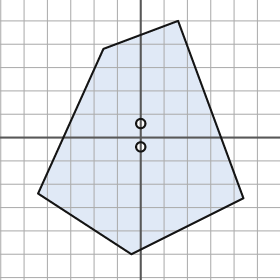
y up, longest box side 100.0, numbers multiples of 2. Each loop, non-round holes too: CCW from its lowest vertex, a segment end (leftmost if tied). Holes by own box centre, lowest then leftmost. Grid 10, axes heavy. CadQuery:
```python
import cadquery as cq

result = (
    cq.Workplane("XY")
    .moveTo(-4.0, -50.0)
    .lineTo(44.0, -26.0)
    .lineTo(16.0, 50.0)
    .lineTo(-16.0, 38.0)
    .lineTo(-44.0, -24.0)
    .close()
    .moveTo(0.0, -4.0)
    .circle(2.0)
    .moveTo(0.0, 6.0)
    .circle(2.0)
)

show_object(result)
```